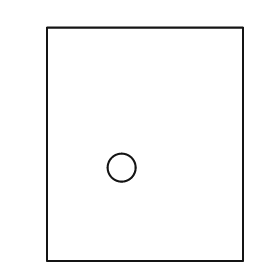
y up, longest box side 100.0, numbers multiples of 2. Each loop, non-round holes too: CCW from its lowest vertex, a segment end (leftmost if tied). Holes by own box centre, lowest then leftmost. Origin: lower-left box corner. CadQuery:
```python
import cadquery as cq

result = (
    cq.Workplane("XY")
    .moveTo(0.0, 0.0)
    .lineTo(84.0, 0.0)
    .lineTo(84.0, 100.0)
    .lineTo(0.0, 100.0)
    .close()
    .moveTo(32.0, 40.0)
    .circle(6.0)
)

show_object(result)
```